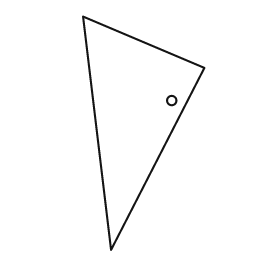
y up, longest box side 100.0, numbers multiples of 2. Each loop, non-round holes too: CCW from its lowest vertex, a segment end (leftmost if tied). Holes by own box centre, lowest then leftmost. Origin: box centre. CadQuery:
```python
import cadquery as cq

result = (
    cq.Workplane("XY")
    .moveTo(-14.0, -50.0)
    .lineTo(26.0, 28.0)
    .lineTo(-26.0, 50.0)
    .close()
    .moveTo(12.0, 14.0)
    .circle(2.0)
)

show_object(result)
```